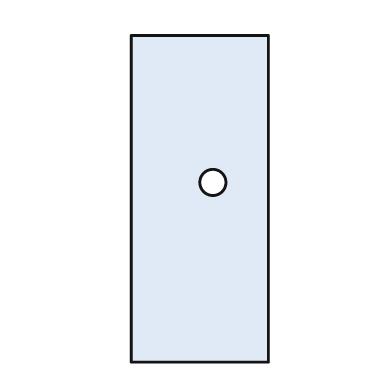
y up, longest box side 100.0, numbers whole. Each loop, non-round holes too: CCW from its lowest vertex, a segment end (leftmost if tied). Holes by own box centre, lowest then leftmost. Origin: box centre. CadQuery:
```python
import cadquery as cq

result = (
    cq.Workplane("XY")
    .moveTo(-21.0, -50.0)
    .lineTo(21.0, -50.0)
    .lineTo(21.0, 50.0)
    .lineTo(-21.0, 50.0)
    .close()
    .moveTo(4.0, 5.0)
    .circle(4.0)
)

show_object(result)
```